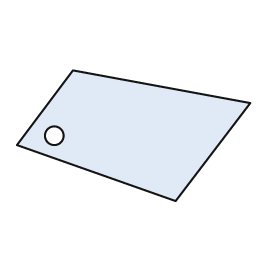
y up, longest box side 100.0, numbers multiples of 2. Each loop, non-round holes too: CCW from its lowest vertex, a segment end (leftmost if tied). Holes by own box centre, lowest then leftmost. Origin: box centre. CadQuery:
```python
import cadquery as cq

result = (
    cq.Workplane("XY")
    .moveTo(18.0, -28.0)
    .lineTo(50.0, 14.0)
    .lineTo(-26.0, 28.0)
    .lineTo(-50.0, -4.0)
    .close()
    .moveTo(-34.0, 0.0)
    .circle(4.0)
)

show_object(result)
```